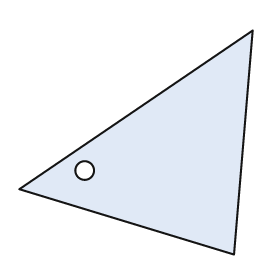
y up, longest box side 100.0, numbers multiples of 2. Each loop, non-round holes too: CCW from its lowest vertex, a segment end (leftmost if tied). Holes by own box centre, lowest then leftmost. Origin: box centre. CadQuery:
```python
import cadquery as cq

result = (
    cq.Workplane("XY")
    .moveTo(42.0, -48.0)
    .lineTo(50.0, 48.0)
    .lineTo(-50.0, -20.0)
    .close()
    .moveTo(-22.0, -12.0)
    .circle(4.0)
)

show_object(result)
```